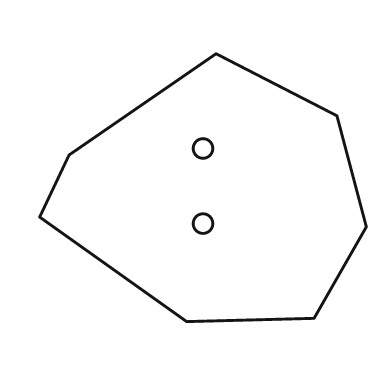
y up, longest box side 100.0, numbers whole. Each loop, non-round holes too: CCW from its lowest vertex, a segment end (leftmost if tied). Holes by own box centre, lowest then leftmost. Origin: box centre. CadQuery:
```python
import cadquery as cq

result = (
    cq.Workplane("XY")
    .moveTo(-5.0, -41.0)
    .lineTo(34.0, -40.0)
    .lineTo(50.0, -12.0)
    .lineTo(41.0, 22.0)
    .lineTo(4.0, 41.0)
    .lineTo(-41.0, 10.0)
    .lineTo(-50.0, -9.0)
    .close()
    .moveTo(0.0, -11.0)
    .circle(3.0)
    .moveTo(0.0, 12.0)
    .circle(3.0)
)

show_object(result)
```